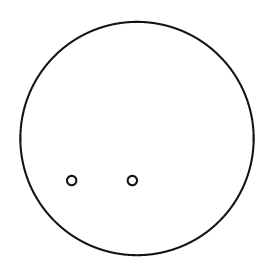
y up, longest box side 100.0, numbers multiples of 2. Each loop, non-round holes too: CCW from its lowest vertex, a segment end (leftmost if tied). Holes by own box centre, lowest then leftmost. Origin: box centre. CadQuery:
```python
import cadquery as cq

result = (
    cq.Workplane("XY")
    .moveTo(0.0, 0.0)
    .circle(50.0)
    .moveTo(-28.0, -18.0)
    .circle(2.0)
    .moveTo(-2.0, -18.0)
    .circle(2.0)
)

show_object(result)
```